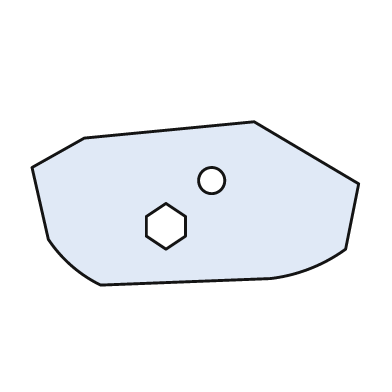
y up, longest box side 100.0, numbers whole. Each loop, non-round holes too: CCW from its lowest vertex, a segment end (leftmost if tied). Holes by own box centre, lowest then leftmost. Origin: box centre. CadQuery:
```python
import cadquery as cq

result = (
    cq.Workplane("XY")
    .moveTo(-29.0, -25.0)
    .lineTo(23.0, -23.0)
    .threePointArc((35.0, -20.0), (46.0, -14.0))
    .lineTo(50.0, 6.0)
    .lineTo(18.0, 25.0)
    .lineTo(-34.0, 20.0)
    .lineTo(-50.0, 11.0)
    .lineTo(-45.0, -11.0)
    .threePointArc((-38.0, -19.0), (-29.0, -25.0))
    .close()
    .moveTo(-9.0, -14.0)
    .lineTo(-3.0, -10.0)
    .lineTo(-3.0, -4.0)
    .lineTo(-9.0, 0.0)
    .lineTo(-15.0, -4.0)
    .lineTo(-15.0, -10.0)
    .close()
    .moveTo(5.0, 7.0)
    .circle(4.0)
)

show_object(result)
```